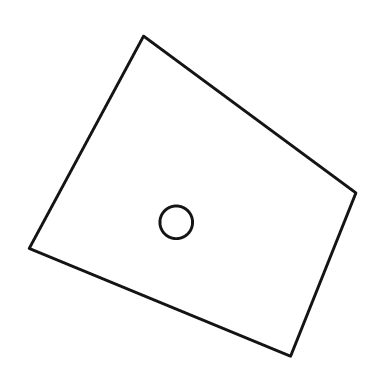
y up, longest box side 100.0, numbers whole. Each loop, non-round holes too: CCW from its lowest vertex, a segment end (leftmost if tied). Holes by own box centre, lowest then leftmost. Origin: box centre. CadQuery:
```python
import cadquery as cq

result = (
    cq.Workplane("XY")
    .moveTo(30.0, -49.0)
    .lineTo(50.0, 1.0)
    .lineTo(-15.0, 49.0)
    .lineTo(-50.0, -16.0)
    .close()
    .moveTo(-5.0, -8.0)
    .circle(5.0)
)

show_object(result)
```